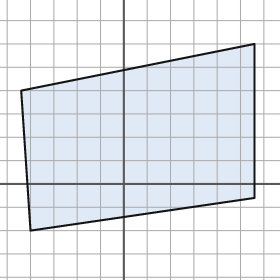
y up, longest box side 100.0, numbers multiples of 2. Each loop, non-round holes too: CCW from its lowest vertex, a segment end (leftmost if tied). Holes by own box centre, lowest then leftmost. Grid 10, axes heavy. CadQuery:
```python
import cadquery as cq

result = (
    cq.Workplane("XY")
    .moveTo(-40.0, -20.0)
    .lineTo(56.0, -6.0)
    .lineTo(56.0, 60.0)
    .lineTo(-44.0, 40.0)
    .close()
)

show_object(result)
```